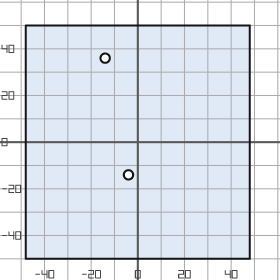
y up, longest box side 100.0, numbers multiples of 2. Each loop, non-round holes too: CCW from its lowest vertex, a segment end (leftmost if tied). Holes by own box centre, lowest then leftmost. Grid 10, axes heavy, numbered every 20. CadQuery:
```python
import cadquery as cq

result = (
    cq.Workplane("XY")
    .moveTo(-48.0, -50.0)
    .lineTo(48.0, -50.0)
    .lineTo(48.0, 50.0)
    .lineTo(-48.0, 50.0)
    .close()
    .moveTo(-4.0, -14.0)
    .circle(2.0)
    .moveTo(-14.0, 36.0)
    .circle(2.0)
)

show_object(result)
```